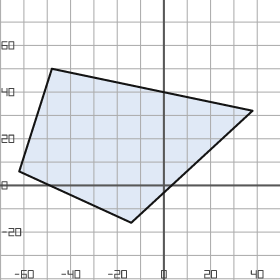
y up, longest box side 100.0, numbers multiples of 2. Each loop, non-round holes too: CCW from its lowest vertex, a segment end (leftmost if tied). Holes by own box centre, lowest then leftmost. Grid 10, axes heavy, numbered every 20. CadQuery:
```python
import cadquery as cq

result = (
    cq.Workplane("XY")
    .moveTo(-14.0, -16.0)
    .lineTo(38.0, 32.0)
    .lineTo(-48.0, 50.0)
    .lineTo(-62.0, 6.0)
    .close()
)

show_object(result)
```